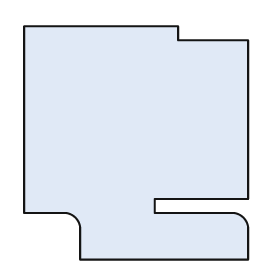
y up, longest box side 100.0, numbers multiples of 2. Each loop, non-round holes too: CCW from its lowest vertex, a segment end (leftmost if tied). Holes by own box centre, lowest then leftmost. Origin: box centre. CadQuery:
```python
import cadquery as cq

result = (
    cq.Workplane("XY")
    .moveTo(-24.0, -50.0)
    .lineTo(48.0, -50.0)
    .lineTo(48.0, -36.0)
    .threePointArc((46.0, -32.0), (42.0, -30.0))
    .lineTo(8.0, -30.0)
    .lineTo(8.0, -24.0)
    .lineTo(48.0, -24.0)
    .lineTo(48.0, 44.0)
    .lineTo(18.0, 44.0)
    .lineTo(18.0, 50.0)
    .lineTo(-48.0, 50.0)
    .lineTo(-48.0, -30.0)
    .lineTo(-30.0, -30.0)
    .threePointArc((-26.0, -32.0), (-24.0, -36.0))
    .close()
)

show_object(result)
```